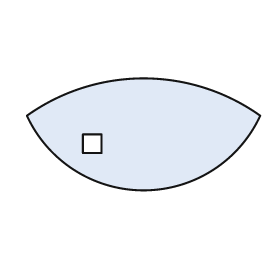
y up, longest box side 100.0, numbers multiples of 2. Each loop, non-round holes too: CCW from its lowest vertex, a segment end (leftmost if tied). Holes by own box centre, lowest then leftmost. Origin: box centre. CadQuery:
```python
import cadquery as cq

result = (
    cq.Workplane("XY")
    .moveTo(-50.0, 8.0)
    .threePointArc((0.0, -24.0), (50.0, 8.0))
    .threePointArc((0.0, 24.0), (-50.0, 8.0))
    .close()
    .moveTo(-26.0, -8.0)
    .lineTo(-18.0, -8.0)
    .lineTo(-18.0, 0.0)
    .lineTo(-26.0, 0.0)
    .close()
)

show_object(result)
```